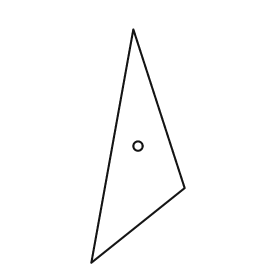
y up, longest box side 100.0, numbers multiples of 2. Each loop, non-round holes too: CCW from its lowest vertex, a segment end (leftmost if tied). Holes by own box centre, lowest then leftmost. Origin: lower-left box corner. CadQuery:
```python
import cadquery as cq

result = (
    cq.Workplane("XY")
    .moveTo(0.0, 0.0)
    .lineTo(40.0, 32.0)
    .lineTo(18.0, 100.0)
    .close()
    .moveTo(20.0, 50.0)
    .circle(2.0)
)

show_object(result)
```